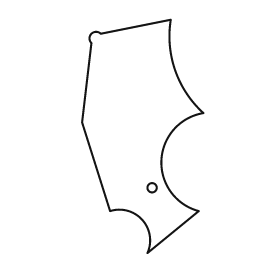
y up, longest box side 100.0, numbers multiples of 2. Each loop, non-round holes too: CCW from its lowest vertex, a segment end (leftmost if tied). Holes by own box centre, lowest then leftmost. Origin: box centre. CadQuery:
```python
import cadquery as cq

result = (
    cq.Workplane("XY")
    .moveTo(2.0, -50.0)
    .lineTo(24.0, -32.0)
    .threePointArc((8.0, -10.0), (26.0, 10.0))
    .threePointArc((14.0, 28.0), (12.0, 50.0))
    .lineTo(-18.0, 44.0)
    .threePointArc((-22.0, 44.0), (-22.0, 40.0))
    .lineTo(-26.0, 6.0)
    .lineTo(-14.0, -32.0)
    .threePointArc((0.0, -36.0), (2.0, -50.0))
    .close()
    .moveTo(4.0, -22.0)
    .circle(2.0)
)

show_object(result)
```